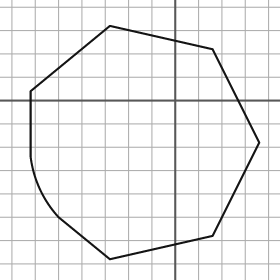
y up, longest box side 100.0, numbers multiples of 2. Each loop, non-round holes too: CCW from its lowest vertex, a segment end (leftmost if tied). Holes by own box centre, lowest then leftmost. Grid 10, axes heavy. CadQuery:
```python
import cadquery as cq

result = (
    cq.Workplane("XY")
    .moveTo(-28.0, -68.0)
    .lineTo(16.0, -58.0)
    .lineTo(36.0, -18.0)
    .lineTo(16.0, 22.0)
    .lineTo(-28.0, 32.0)
    .lineTo(-62.0, 4.0)
    .lineTo(-62.0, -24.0)
    .threePointArc((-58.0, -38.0), (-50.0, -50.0))
    .close()
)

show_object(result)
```